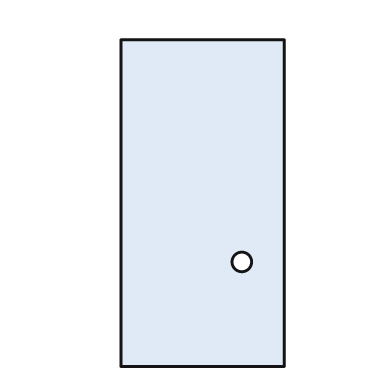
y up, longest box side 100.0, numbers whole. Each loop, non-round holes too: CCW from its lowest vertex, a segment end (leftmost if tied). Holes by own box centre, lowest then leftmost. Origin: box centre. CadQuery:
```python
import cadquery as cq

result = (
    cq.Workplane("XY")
    .moveTo(-25.0, -50.0)
    .lineTo(25.0, -50.0)
    .lineTo(25.0, 50.0)
    .lineTo(-25.0, 50.0)
    .close()
    .moveTo(12.0, -18.0)
    .circle(3.0)
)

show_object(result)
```